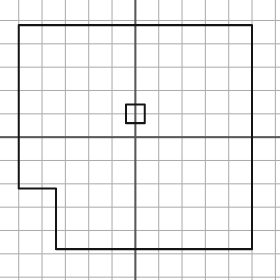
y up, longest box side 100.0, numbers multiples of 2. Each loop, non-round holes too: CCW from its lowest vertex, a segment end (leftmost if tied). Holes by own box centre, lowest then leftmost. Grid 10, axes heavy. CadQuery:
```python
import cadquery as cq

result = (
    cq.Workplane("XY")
    .moveTo(-34.0, -48.0)
    .lineTo(50.0, -48.0)
    .lineTo(50.0, 48.0)
    .lineTo(-50.0, 48.0)
    .lineTo(-50.0, -22.0)
    .lineTo(-34.0, -22.0)
    .close()
    .moveTo(-4.0, 6.0)
    .lineTo(4.0, 6.0)
    .lineTo(4.0, 14.0)
    .lineTo(-4.0, 14.0)
    .close()
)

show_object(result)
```